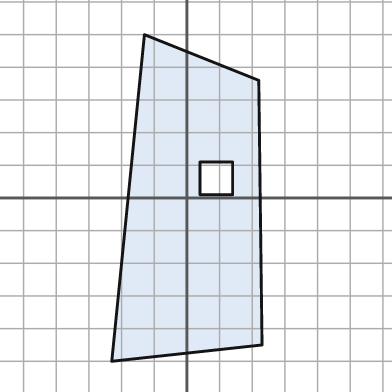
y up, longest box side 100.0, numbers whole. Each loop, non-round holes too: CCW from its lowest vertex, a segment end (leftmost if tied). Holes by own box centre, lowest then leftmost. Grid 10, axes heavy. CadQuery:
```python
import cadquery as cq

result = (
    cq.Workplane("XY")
    .moveTo(-23.0, -50.0)
    .lineTo(23.0, -45.0)
    .lineTo(22.0, 36.0)
    .lineTo(-13.0, 50.0)
    .close()
    .moveTo(4.0, 1.0)
    .lineTo(14.0, 1.0)
    .lineTo(14.0, 11.0)
    .lineTo(4.0, 11.0)
    .close()
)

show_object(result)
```